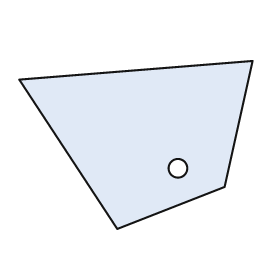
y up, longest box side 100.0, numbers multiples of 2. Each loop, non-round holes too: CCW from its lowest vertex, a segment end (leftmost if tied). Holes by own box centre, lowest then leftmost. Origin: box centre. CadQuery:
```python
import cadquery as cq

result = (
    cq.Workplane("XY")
    .moveTo(-8.0, -36.0)
    .lineTo(38.0, -18.0)
    .lineTo(50.0, 36.0)
    .lineTo(-50.0, 28.0)
    .close()
    .moveTo(18.0, -10.0)
    .circle(4.0)
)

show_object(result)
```